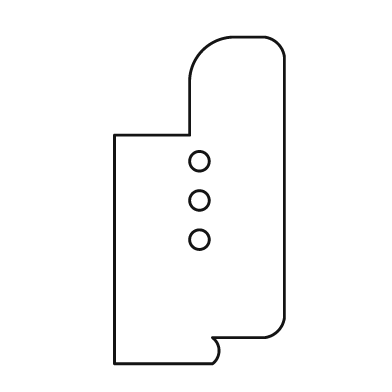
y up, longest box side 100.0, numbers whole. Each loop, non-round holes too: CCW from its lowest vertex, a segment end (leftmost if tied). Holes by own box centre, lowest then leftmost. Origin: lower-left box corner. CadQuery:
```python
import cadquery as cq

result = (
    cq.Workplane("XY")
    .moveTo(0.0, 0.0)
    .lineTo(30.0, 0.0)
    .threePointArc((32.0, 4.0), (30.0, 8.0))
    .lineTo(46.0, 8.0)
    .threePointArc((50.0, 10.0), (52.0, 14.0))
    .lineTo(52.0, 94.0)
    .threePointArc((50.0, 98.0), (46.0, 100.0))
    .lineTo(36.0, 100.0)
    .threePointArc((27.0, 96.0), (23.0, 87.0))
    .lineTo(23.0, 70.0)
    .lineTo(0.0, 70.0)
    .close()
    .moveTo(26.0, 38.0)
    .circle(3.0)
    .moveTo(26.0, 50.0)
    .circle(3.0)
    .moveTo(26.0, 62.0)
    .circle(3.0)
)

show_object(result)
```